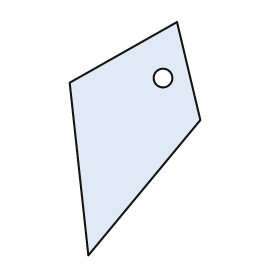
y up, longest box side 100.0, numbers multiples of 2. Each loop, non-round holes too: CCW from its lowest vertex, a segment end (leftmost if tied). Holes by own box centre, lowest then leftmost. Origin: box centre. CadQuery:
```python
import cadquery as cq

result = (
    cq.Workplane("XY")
    .moveTo(-20.0, -50.0)
    .lineTo(28.0, 8.0)
    .lineTo(18.0, 50.0)
    .lineTo(-28.0, 24.0)
    .close()
    .moveTo(12.0, 26.0)
    .circle(4.0)
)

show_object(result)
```